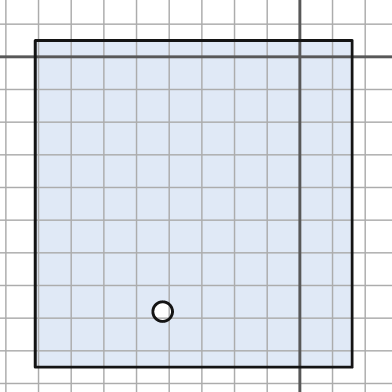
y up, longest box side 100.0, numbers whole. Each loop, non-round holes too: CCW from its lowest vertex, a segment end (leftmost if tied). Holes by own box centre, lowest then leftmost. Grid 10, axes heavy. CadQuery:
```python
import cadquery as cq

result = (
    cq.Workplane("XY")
    .moveTo(-81.0, -95.0)
    .lineTo(16.0, -95.0)
    .lineTo(16.0, 5.0)
    .lineTo(-81.0, 5.0)
    .close()
    .moveTo(-42.0, -78.0)
    .circle(3.0)
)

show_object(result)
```